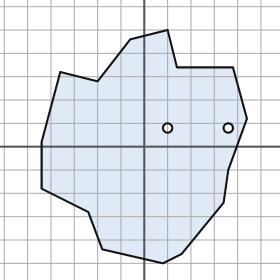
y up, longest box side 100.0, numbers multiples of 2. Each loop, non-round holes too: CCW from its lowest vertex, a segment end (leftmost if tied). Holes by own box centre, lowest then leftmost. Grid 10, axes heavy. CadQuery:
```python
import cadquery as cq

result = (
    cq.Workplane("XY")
    .moveTo(8.0, -50.0)
    .lineTo(16.0, -46.0)
    .lineTo(34.0, -24.0)
    .lineTo(36.0, -10.0)
    .lineTo(44.0, 12.0)
    .lineTo(38.0, 34.0)
    .lineTo(14.0, 34.0)
    .lineTo(10.0, 50.0)
    .lineTo(-6.0, 46.0)
    .lineTo(-20.0, 28.0)
    .lineTo(-36.0, 32.0)
    .lineTo(-44.0, 2.0)
    .lineTo(-44.0, -18.0)
    .lineTo(-24.0, -28.0)
    .lineTo(-18.0, -44.0)
    .close()
    .moveTo(10.0, 8.0)
    .circle(2.0)
    .moveTo(36.0, 8.0)
    .circle(2.0)
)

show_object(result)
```